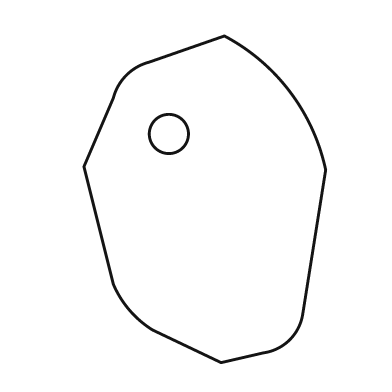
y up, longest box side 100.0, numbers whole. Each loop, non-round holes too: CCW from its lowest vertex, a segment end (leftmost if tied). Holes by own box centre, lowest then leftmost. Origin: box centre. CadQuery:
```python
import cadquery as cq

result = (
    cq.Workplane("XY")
    .moveTo(5.0, -50.0)
    .lineTo(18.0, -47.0)
    .threePointArc((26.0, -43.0), (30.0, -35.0))
    .lineTo(37.0, 9.0)
    .threePointArc((26.0, 33.0), (6.0, 50.0))
    .lineTo(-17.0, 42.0)
    .threePointArc((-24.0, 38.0), (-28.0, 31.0))
    .lineTo(-37.0, 10.0)
    .lineTo(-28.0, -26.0)
    .threePointArc((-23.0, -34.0), (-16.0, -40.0))
    .close()
    .moveTo(-11.0, 20.0)
    .circle(6.0)
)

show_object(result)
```